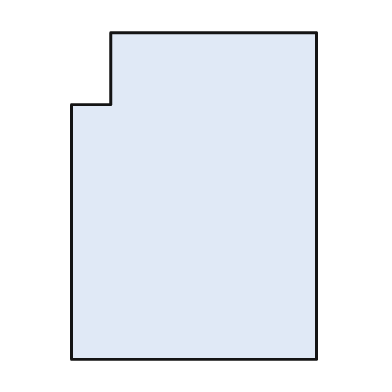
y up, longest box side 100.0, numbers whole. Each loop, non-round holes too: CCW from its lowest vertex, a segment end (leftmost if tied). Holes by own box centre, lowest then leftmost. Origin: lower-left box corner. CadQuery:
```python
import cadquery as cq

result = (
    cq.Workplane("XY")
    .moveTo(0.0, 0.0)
    .lineTo(75.0, 0.0)
    .lineTo(75.0, 100.0)
    .lineTo(12.0, 100.0)
    .lineTo(12.0, 78.0)
    .lineTo(0.0, 78.0)
    .close()
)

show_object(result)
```